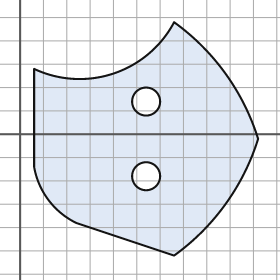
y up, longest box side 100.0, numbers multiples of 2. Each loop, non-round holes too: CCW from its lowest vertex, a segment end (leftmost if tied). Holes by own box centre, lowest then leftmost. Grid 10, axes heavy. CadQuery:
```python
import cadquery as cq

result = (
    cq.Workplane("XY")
    .moveTo(66.0, -52.0)
    .threePointArc((88.0, -30.0), (102.0, -2.0))
    .threePointArc((88.0, 26.0), (66.0, 48.0))
    .threePointArc((40.0, 26.0), (6.0, 28.0))
    .lineTo(6.0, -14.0)
    .threePointArc((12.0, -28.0), (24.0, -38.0))
    .close()
    .moveTo(54.0, -18.0)
    .circle(6.0)
    .moveTo(54.0, 14.0)
    .circle(6.0)
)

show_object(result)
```